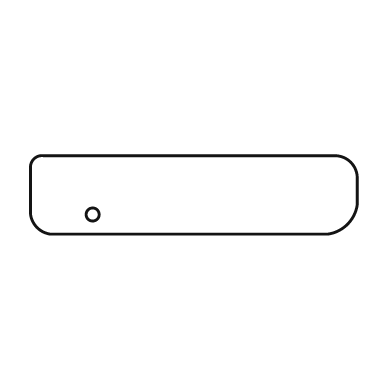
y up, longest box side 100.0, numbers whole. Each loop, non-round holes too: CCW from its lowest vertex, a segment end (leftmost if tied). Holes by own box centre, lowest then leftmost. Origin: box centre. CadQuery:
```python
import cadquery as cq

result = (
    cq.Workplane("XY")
    .moveTo(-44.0, -12.0)
    .lineTo(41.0, -12.0)
    .threePointArc((47.0, -9.0), (50.0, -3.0))
    .lineTo(50.0, 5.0)
    .threePointArc((48.0, 10.0), (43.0, 12.0))
    .lineTo(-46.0, 12.0)
    .threePointArc((-49.0, 11.0), (-50.0, 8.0))
    .lineTo(-50.0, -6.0)
    .threePointArc((-48.0, -10.0), (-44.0, -12.0))
    .close()
    .moveTo(-31.0, -6.0)
    .circle(2.0)
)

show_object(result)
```